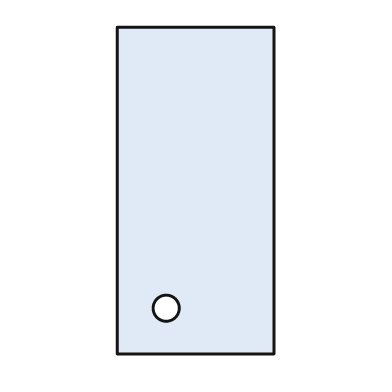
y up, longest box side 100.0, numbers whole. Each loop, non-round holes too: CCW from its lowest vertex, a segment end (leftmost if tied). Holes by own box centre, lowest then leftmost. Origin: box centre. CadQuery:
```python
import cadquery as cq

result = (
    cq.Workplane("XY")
    .moveTo(-24.0, -50.0)
    .lineTo(24.0, -50.0)
    .lineTo(24.0, 50.0)
    .lineTo(-24.0, 50.0)
    .close()
    .moveTo(-9.0, -36.0)
    .circle(4.0)
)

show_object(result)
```